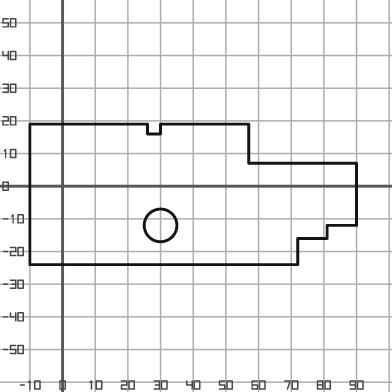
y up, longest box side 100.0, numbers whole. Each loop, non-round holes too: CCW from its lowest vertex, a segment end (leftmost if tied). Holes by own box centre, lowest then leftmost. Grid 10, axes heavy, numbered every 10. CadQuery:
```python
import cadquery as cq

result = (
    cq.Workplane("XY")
    .moveTo(-10.0, -24.0)
    .lineTo(72.0, -24.0)
    .lineTo(72.0, -16.0)
    .lineTo(81.0, -16.0)
    .lineTo(81.0, -12.0)
    .lineTo(90.0, -12.0)
    .lineTo(90.0, 7.0)
    .lineTo(57.0, 7.0)
    .lineTo(57.0, 19.0)
    .lineTo(30.0, 19.0)
    .lineTo(30.0, 16.0)
    .lineTo(26.0, 16.0)
    .lineTo(26.0, 19.0)
    .lineTo(-10.0, 19.0)
    .close()
    .moveTo(30.0, -12.0)
    .circle(5.0)
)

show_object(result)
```